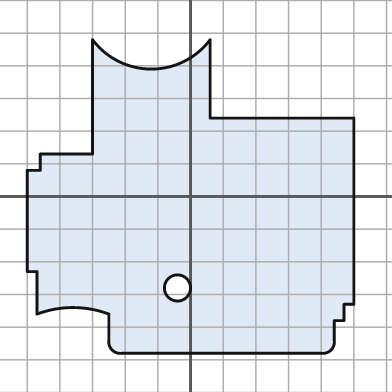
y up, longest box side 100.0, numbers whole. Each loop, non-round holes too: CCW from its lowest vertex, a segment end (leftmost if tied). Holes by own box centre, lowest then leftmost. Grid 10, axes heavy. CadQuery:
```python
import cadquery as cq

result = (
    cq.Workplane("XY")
    .moveTo(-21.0, -48.0)
    .lineTo(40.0, -48.0)
    .threePointArc((43.0, -47.0), (44.0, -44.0))
    .lineTo(44.0, -38.0)
    .lineTo(47.0, -38.0)
    .lineTo(47.0, -33.0)
    .lineTo(50.0, -33.0)
    .lineTo(50.0, 24.0)
    .lineTo(6.0, 24.0)
    .lineTo(6.0, 48.0)
    .threePointArc((-12.0, 39.0), (-30.0, 48.0))
    .lineTo(-30.0, 13.0)
    .lineTo(-46.0, 13.0)
    .lineTo(-46.0, 8.0)
    .lineTo(-50.0, 8.0)
    .lineTo(-50.0, -23.0)
    .lineTo(-47.0, -23.0)
    .lineTo(-47.0, -36.0)
    .threePointArc((-36.0, -34.0), (-25.0, -36.0))
    .lineTo(-25.0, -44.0)
    .threePointArc((-24.0, -47.0), (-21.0, -48.0))
    .close()
    .moveTo(-4.0, -28.0)
    .circle(4.0)
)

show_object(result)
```